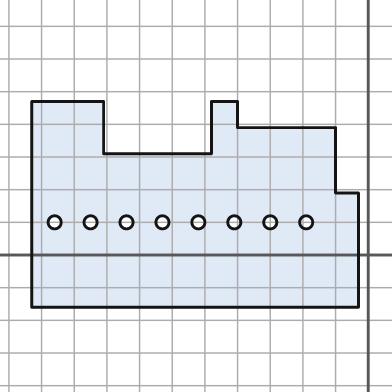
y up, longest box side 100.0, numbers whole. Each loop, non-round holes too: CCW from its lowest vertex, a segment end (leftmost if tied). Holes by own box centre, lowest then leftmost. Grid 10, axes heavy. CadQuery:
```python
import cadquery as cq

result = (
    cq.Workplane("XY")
    .moveTo(-103.0, -16.0)
    .lineTo(-3.0, -16.0)
    .lineTo(-3.0, 19.0)
    .lineTo(-10.0, 19.0)
    .lineTo(-10.0, 39.0)
    .lineTo(-40.0, 39.0)
    .lineTo(-40.0, 47.0)
    .lineTo(-48.0, 47.0)
    .lineTo(-48.0, 31.0)
    .lineTo(-81.0, 31.0)
    .lineTo(-81.0, 47.0)
    .lineTo(-103.0, 47.0)
    .close()
    .moveTo(-96.0, 10.0)
    .circle(2.0)
    .moveTo(-85.0, 10.0)
    .circle(2.0)
    .moveTo(-74.0, 10.0)
    .circle(2.0)
    .moveTo(-63.0, 10.0)
    .circle(2.0)
    .moveTo(-52.0, 10.0)
    .circle(2.0)
    .moveTo(-41.0, 10.0)
    .circle(2.0)
    .moveTo(-30.0, 10.0)
    .circle(2.0)
    .moveTo(-19.0, 10.0)
    .circle(2.0)
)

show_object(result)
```